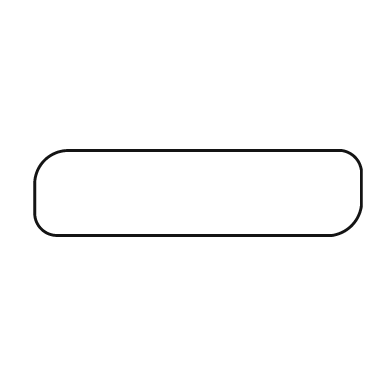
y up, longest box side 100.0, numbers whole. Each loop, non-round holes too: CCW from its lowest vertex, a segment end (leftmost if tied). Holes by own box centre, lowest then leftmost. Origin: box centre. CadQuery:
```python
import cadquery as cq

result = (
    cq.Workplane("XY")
    .moveTo(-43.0, -13.0)
    .lineTo(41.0, -13.0)
    .threePointArc((47.0, -10.0), (50.0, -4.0))
    .lineTo(50.0, 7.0)
    .threePointArc((48.0, 11.0), (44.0, 13.0))
    .lineTo(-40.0, 13.0)
    .threePointArc((-47.0, 10.0), (-50.0, 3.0))
    .lineTo(-50.0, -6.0)
    .threePointArc((-48.0, -11.0), (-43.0, -13.0))
    .close()
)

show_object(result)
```